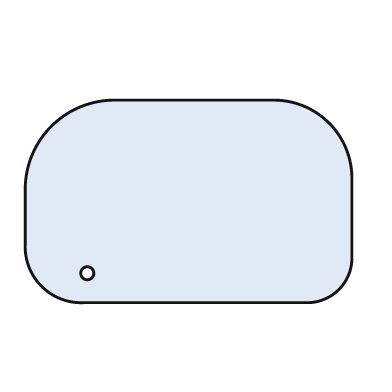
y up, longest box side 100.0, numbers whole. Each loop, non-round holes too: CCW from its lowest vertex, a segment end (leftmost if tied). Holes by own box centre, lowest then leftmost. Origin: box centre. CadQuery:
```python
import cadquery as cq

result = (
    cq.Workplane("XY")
    .moveTo(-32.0, -31.0)
    .lineTo(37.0, -31.0)
    .threePointArc((46.0, -27.0), (50.0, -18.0))
    .lineTo(50.0, 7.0)
    .threePointArc((43.0, 24.0), (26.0, 31.0))
    .lineTo(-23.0, 31.0)
    .threePointArc((-42.0, 23.0), (-50.0, 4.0))
    .lineTo(-50.0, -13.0)
    .threePointArc((-45.0, -26.0), (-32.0, -31.0))
    .close()
    .moveTo(-31.0, -22.0)
    .circle(2.0)
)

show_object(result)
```